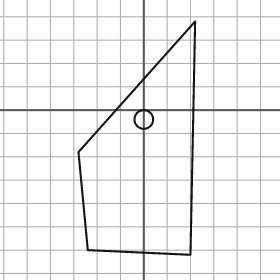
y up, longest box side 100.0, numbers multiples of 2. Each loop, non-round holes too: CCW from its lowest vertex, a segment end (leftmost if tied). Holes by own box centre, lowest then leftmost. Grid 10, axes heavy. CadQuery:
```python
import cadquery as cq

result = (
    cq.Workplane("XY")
    .moveTo(20.0, -62.0)
    .lineTo(22.0, 38.0)
    .lineTo(-28.0, -18.0)
    .lineTo(-24.0, -60.0)
    .close()
    .moveTo(0.0, -4.0)
    .circle(4.0)
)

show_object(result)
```